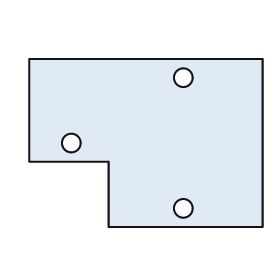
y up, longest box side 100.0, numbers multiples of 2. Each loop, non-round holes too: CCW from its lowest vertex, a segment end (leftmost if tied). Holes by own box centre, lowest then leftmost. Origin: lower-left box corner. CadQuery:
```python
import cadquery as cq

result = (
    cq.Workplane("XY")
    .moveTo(34.0, 0.0)
    .lineTo(100.0, 0.0)
    .lineTo(100.0, 72.0)
    .lineTo(0.0, 72.0)
    .lineTo(0.0, 28.0)
    .lineTo(34.0, 28.0)
    .close()
    .moveTo(66.0, 8.0)
    .circle(4.0)
    .moveTo(18.0, 36.0)
    .circle(4.0)
    .moveTo(66.0, 64.0)
    .circle(4.0)
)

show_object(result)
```